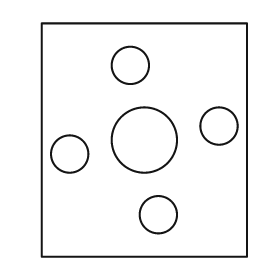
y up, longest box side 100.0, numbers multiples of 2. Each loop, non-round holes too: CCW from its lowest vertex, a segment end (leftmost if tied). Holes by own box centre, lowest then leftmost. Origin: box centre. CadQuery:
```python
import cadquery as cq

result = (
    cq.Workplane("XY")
    .moveTo(-44.0, -50.0)
    .lineTo(44.0, -50.0)
    .lineTo(44.0, 50.0)
    .lineTo(-44.0, 50.0)
    .close()
    .moveTo(6.0, -32.0)
    .circle(8.0)
    .moveTo(-32.0, -6.0)
    .circle(8.0)
    .moveTo(0.0, 0.0)
    .circle(14.0)
    .moveTo(32.0, 6.0)
    .circle(8.0)
    .moveTo(-6.0, 32.0)
    .circle(8.0)
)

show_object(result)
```